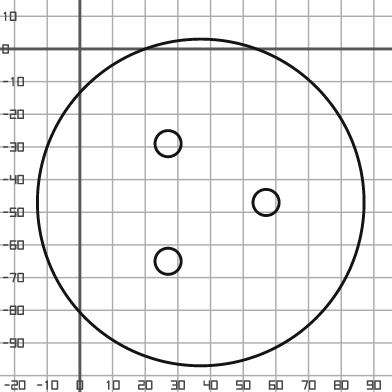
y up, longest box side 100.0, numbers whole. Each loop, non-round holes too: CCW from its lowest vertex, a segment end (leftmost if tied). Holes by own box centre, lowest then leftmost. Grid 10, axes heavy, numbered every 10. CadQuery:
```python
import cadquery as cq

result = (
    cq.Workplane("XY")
    .moveTo(37.0, -47.0)
    .circle(50.0)
    .moveTo(27.0, -65.0)
    .circle(4.0)
    .moveTo(57.0, -47.0)
    .circle(4.0)
    .moveTo(27.0, -29.0)
    .circle(4.0)
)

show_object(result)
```